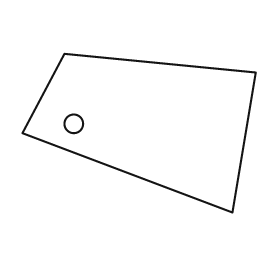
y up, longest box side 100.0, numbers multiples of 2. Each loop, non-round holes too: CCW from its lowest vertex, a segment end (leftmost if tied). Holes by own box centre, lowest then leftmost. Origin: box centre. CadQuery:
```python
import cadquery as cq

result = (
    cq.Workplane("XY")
    .moveTo(40.0, -34.0)
    .lineTo(50.0, 26.0)
    .lineTo(-32.0, 34.0)
    .lineTo(-50.0, 0.0)
    .close()
    .moveTo(-28.0, 4.0)
    .circle(4.0)
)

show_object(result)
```